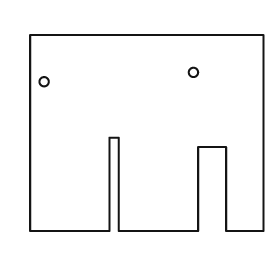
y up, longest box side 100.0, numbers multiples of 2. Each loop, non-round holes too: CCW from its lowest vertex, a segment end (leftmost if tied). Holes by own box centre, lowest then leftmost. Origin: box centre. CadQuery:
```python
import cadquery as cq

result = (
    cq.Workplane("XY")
    .moveTo(-50.0, -42.0)
    .lineTo(-16.0, -42.0)
    .lineTo(-16.0, -2.0)
    .lineTo(-12.0, -2.0)
    .lineTo(-12.0, -42.0)
    .lineTo(22.0, -42.0)
    .lineTo(22.0, -6.0)
    .lineTo(34.0, -6.0)
    .lineTo(34.0, -42.0)
    .lineTo(50.0, -42.0)
    .lineTo(50.0, 42.0)
    .lineTo(-50.0, 42.0)
    .close()
    .moveTo(-44.0, 22.0)
    .circle(2.0)
    .moveTo(20.0, 26.0)
    .circle(2.0)
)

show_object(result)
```